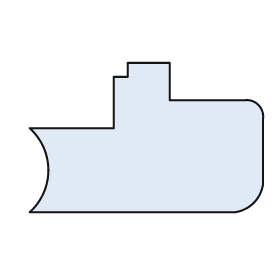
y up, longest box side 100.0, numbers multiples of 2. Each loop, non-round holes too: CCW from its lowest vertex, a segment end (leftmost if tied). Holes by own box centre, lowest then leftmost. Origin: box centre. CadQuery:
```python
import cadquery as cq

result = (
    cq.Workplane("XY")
    .moveTo(-50.0, -32.0)
    .lineTo(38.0, -32.0)
    .threePointArc((46.0, -28.0), (50.0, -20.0))
    .lineTo(50.0, 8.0)
    .threePointArc((48.0, 14.0), (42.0, 16.0))
    .lineTo(10.0, 16.0)
    .lineTo(10.0, 32.0)
    .lineTo(-8.0, 32.0)
    .lineTo(-8.0, 26.0)
    .lineTo(-14.0, 26.0)
    .lineTo(-14.0, 4.0)
    .lineTo(-50.0, 4.0)
    .threePointArc((-42.0, -14.0), (-50.0, -32.0))
    .close()
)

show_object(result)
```